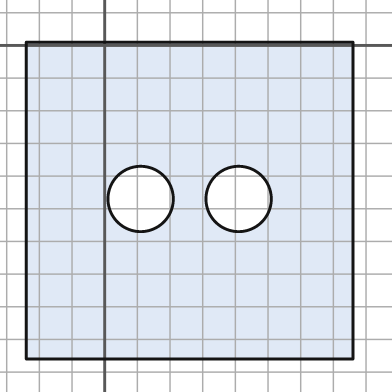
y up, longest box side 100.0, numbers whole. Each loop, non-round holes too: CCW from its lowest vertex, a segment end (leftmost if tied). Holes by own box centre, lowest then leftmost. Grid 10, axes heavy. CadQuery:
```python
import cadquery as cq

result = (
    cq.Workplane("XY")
    .moveTo(-24.0, -96.0)
    .lineTo(76.0, -96.0)
    .lineTo(76.0, 1.0)
    .lineTo(-24.0, 1.0)
    .close()
    .moveTo(11.0, -47.0)
    .circle(10.0)
    .moveTo(41.0, -47.0)
    .circle(10.0)
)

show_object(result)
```